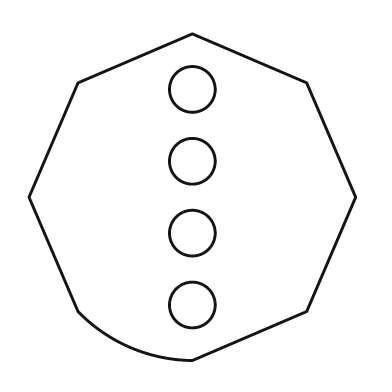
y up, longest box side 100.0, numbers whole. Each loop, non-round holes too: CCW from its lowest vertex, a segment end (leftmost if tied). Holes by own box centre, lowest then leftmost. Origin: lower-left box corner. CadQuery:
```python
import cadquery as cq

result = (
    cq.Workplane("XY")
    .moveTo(50.0, 0.0)
    .lineTo(85.0, 15.0)
    .lineTo(100.0, 50.0)
    .lineTo(85.0, 85.0)
    .lineTo(50.0, 100.0)
    .lineTo(15.0, 85.0)
    .lineTo(0.0, 50.0)
    .lineTo(15.0, 15.0)
    .threePointArc((31.0, 4.0), (50.0, 0.0))
    .close()
    .moveTo(50.0, 17.0)
    .circle(7.0)
    .moveTo(50.0, 39.0)
    .circle(7.0)
    .moveTo(50.0, 61.0)
    .circle(7.0)
    .moveTo(50.0, 83.0)
    .circle(7.0)
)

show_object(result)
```